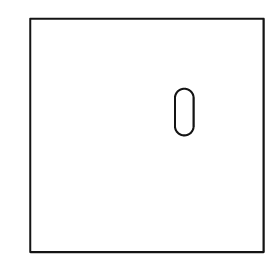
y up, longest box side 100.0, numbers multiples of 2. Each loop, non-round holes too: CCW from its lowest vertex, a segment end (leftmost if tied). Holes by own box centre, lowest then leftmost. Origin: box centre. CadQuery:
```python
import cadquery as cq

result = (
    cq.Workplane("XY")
    .moveTo(-50.0, -50.0)
    .lineTo(50.0, -50.0)
    .lineTo(50.0, 50.0)
    .lineTo(-50.0, 50.0)
    .close()
    .moveTo(12.0, 4.0)
    .threePointArc((16.0, 0.0), (20.0, 4.0))
    .lineTo(20.0, 16.0)
    .threePointArc((16.0, 20.0), (12.0, 16.0))
    .close()
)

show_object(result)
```